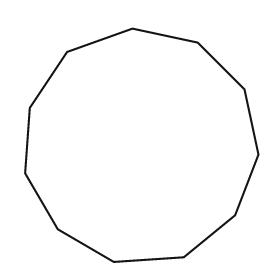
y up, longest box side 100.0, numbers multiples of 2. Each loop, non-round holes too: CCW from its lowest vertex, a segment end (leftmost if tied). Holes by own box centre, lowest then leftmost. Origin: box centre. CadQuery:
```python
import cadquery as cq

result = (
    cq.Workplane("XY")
    .moveTo(-12.0, -50.0)
    .lineTo(18.0, -48.0)
    .lineTo(40.0, -30.0)
    .lineTo(50.0, -4.0)
    .lineTo(44.0, 24.0)
    .lineTo(24.0, 44.0)
    .lineTo(-4.0, 50.0)
    .lineTo(-32.0, 40.0)
    .lineTo(-48.0, 16.0)
    .lineTo(-50.0, -12.0)
    .lineTo(-36.0, -36.0)
    .close()
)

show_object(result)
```